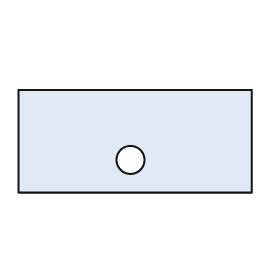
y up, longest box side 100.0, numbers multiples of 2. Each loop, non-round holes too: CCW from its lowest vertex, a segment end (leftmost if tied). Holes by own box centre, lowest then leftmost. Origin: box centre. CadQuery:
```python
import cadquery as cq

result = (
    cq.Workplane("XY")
    .moveTo(-50.0, -22.0)
    .lineTo(50.0, -22.0)
    .lineTo(50.0, 22.0)
    .lineTo(-50.0, 22.0)
    .close()
    .moveTo(-2.0, -8.0)
    .circle(6.0)
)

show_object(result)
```